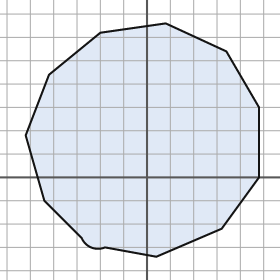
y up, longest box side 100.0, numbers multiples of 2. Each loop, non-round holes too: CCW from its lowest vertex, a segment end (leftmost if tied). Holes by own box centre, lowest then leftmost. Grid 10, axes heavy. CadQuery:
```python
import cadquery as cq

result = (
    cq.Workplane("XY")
    .moveTo(4.0, -34.0)
    .lineTo(32.0, -22.0)
    .lineTo(48.0, 0.0)
    .lineTo(48.0, 30.0)
    .lineTo(34.0, 54.0)
    .lineTo(8.0, 66.0)
    .lineTo(-20.0, 62.0)
    .lineTo(-42.0, 44.0)
    .lineTo(-52.0, 18.0)
    .lineTo(-44.0, -10.0)
    .lineTo(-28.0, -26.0)
    .threePointArc((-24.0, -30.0), (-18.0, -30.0))
    .close()
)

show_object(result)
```